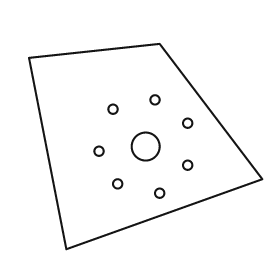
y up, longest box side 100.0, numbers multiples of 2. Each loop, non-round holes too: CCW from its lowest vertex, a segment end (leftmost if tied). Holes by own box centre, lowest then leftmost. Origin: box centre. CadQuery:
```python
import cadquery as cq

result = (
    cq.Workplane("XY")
    .moveTo(-34.0, -44.0)
    .lineTo(50.0, -14.0)
    .lineTo(6.0, 44.0)
    .lineTo(-50.0, 38.0)
    .close()
    .moveTo(6.0, -20.0)
    .circle(2.0)
    .moveTo(-12.0, -16.0)
    .circle(2.0)
    .moveTo(18.0, -8.0)
    .circle(2.0)
    .moveTo(-20.0, -2.0)
    .circle(2.0)
    .moveTo(0.0, 0.0)
    .circle(6.0)
    .moveTo(18.0, 10.0)
    .circle(2.0)
    .moveTo(-14.0, 16.0)
    .circle(2.0)
    .moveTo(4.0, 20.0)
    .circle(2.0)
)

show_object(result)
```